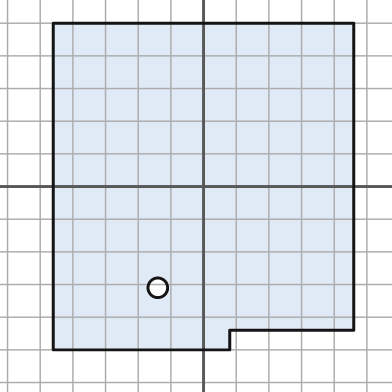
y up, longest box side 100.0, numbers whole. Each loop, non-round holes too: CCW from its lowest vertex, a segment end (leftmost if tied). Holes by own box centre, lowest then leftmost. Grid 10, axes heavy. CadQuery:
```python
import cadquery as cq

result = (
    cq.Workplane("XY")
    .moveTo(-46.0, -50.0)
    .lineTo(8.0, -50.0)
    .lineTo(8.0, -44.0)
    .lineTo(46.0, -44.0)
    .lineTo(46.0, 50.0)
    .lineTo(-46.0, 50.0)
    .close()
    .moveTo(-14.0, -31.0)
    .circle(3.0)
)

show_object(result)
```